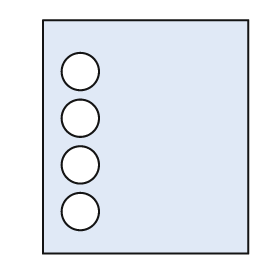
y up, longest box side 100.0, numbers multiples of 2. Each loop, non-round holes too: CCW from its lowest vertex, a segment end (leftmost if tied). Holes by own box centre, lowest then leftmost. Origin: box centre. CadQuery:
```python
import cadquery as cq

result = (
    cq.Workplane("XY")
    .moveTo(-44.0, -50.0)
    .lineTo(44.0, -50.0)
    .lineTo(44.0, 50.0)
    .lineTo(-44.0, 50.0)
    .close()
    .moveTo(-28.0, -32.0)
    .circle(8.0)
    .moveTo(-28.0, -12.0)
    .circle(8.0)
    .moveTo(-28.0, 8.0)
    .circle(8.0)
    .moveTo(-28.0, 28.0)
    .circle(8.0)
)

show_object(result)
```